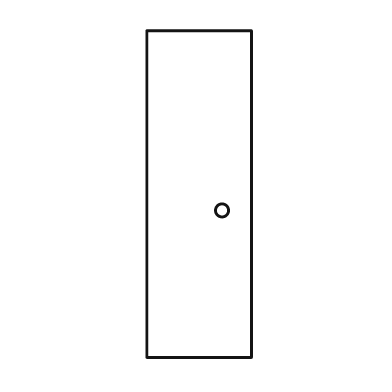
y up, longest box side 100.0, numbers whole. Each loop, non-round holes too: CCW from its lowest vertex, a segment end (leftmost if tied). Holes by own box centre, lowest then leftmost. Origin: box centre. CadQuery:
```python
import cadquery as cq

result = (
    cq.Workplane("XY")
    .moveTo(-16.0, -50.0)
    .lineTo(16.0, -50.0)
    .lineTo(16.0, 50.0)
    .lineTo(-16.0, 50.0)
    .close()
    .moveTo(7.0, -5.0)
    .circle(2.0)
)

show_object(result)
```